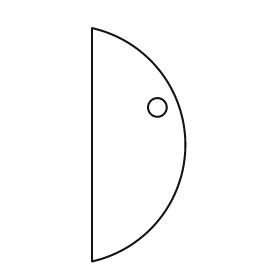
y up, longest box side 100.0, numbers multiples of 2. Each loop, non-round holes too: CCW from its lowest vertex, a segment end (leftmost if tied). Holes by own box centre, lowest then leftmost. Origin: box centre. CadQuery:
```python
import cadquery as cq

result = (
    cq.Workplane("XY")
    .moveTo(-20.0, -50.0)
    .threePointArc((20.0, 0.0), (-20.0, 50.0))
    .close()
    .moveTo(8.0, 16.0)
    .circle(4.0)
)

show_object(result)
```